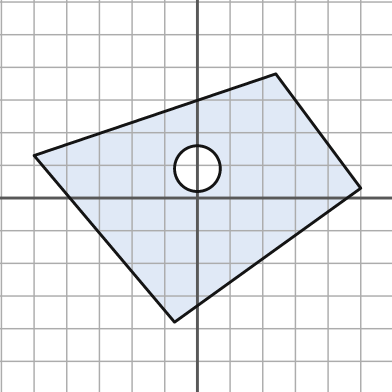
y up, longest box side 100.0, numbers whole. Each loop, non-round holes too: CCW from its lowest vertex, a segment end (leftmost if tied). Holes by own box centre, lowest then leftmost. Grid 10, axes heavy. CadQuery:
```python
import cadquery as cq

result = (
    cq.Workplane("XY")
    .moveTo(-7.0, -38.0)
    .lineTo(50.0, 3.0)
    .lineTo(24.0, 38.0)
    .lineTo(-50.0, 13.0)
    .close()
    .moveTo(0.0, 9.0)
    .circle(7.0)
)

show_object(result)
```